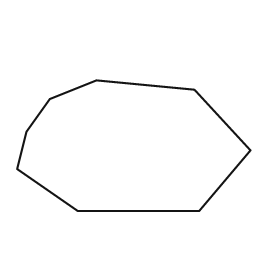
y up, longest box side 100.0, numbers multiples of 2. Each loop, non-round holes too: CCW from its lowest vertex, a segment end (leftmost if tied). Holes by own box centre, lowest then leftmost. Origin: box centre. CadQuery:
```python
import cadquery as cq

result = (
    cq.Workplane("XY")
    .moveTo(-24.0, -28.0)
    .lineTo(28.0, -28.0)
    .lineTo(50.0, -2.0)
    .lineTo(26.0, 24.0)
    .lineTo(-16.0, 28.0)
    .lineTo(-36.0, 20.0)
    .lineTo(-46.0, 6.0)
    .lineTo(-50.0, -10.0)
    .close()
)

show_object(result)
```